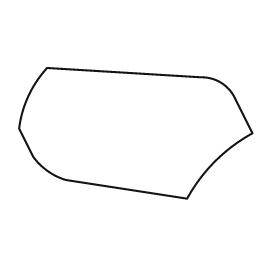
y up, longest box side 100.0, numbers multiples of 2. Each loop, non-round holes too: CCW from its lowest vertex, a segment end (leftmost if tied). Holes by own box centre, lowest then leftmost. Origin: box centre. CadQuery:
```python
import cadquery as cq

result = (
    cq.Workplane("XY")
    .moveTo(22.0, -28.0)
    .threePointArc((34.0, -12.0), (50.0, 0.0))
    .lineTo(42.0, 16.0)
    .threePointArc((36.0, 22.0), (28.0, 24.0))
    .lineTo(-38.0, 28.0)
    .threePointArc((-46.0, 16.0), (-50.0, 2.0))
    .lineTo(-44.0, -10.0)
    .threePointArc((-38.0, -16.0), (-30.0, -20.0))
    .close()
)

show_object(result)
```